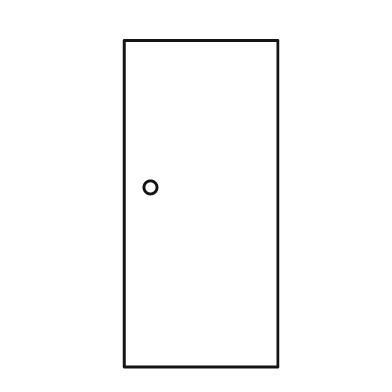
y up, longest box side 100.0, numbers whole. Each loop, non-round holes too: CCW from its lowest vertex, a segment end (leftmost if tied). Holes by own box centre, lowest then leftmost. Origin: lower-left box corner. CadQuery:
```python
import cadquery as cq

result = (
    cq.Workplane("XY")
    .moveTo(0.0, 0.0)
    .lineTo(47.0, 0.0)
    .lineTo(47.0, 100.0)
    .lineTo(0.0, 100.0)
    .close()
    .moveTo(8.0, 55.0)
    .circle(2.0)
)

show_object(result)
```